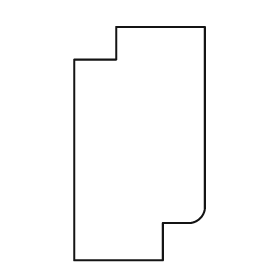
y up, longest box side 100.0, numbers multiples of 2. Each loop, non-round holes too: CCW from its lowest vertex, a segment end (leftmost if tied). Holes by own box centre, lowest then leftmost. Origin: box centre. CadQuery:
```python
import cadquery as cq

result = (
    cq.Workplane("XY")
    .moveTo(-28.0, -50.0)
    .lineTo(10.0, -50.0)
    .lineTo(10.0, -34.0)
    .lineTo(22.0, -34.0)
    .threePointArc((26.0, -32.0), (28.0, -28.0))
    .lineTo(28.0, 50.0)
    .lineTo(-10.0, 50.0)
    .lineTo(-10.0, 36.0)
    .lineTo(-28.0, 36.0)
    .close()
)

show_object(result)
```